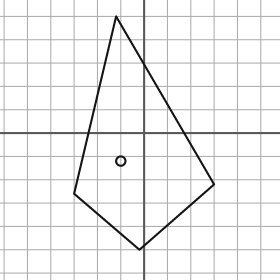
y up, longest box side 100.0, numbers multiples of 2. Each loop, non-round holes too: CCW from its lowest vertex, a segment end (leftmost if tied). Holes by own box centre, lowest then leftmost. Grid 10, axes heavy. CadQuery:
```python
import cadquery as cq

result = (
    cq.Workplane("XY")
    .moveTo(-2.0, -50.0)
    .lineTo(30.0, -22.0)
    .lineTo(-12.0, 50.0)
    .lineTo(-30.0, -26.0)
    .close()
    .moveTo(-10.0, -12.0)
    .circle(2.0)
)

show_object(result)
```